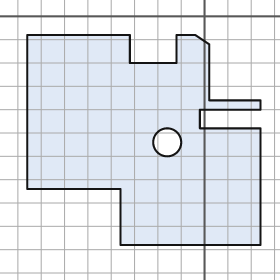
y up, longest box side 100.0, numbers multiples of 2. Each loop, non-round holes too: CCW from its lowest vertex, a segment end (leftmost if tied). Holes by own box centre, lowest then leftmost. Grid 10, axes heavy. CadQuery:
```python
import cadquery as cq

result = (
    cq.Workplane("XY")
    .moveTo(-36.0, -98.0)
    .lineTo(24.0, -98.0)
    .lineTo(24.0, -48.0)
    .lineTo(-2.0, -48.0)
    .lineTo(-2.0, -40.0)
    .lineTo(24.0, -40.0)
    .lineTo(24.0, -36.0)
    .lineTo(2.0, -36.0)
    .lineTo(2.0, -12.0)
    .lineTo(-4.0, -8.0)
    .lineTo(-12.0, -8.0)
    .lineTo(-12.0, -20.0)
    .lineTo(-32.0, -20.0)
    .lineTo(-32.0, -8.0)
    .lineTo(-76.0, -8.0)
    .lineTo(-76.0, -74.0)
    .lineTo(-36.0, -74.0)
    .close()
    .moveTo(-16.0, -54.0)
    .circle(6.0)
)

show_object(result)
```